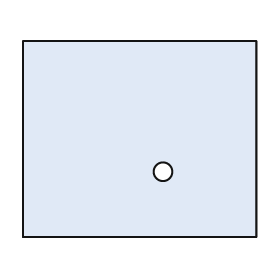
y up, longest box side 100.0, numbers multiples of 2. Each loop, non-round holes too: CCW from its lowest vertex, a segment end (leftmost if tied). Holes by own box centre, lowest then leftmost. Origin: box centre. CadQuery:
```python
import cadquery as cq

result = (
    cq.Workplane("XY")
    .moveTo(-50.0, -42.0)
    .lineTo(50.0, -42.0)
    .lineTo(50.0, 42.0)
    .lineTo(-50.0, 42.0)
    .close()
    .moveTo(10.0, -14.0)
    .circle(4.0)
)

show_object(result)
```